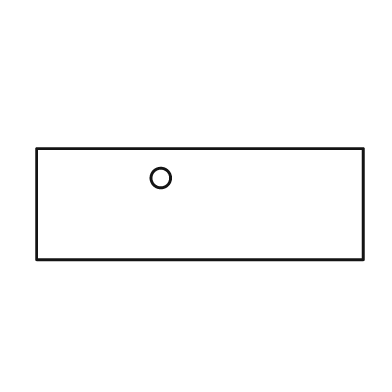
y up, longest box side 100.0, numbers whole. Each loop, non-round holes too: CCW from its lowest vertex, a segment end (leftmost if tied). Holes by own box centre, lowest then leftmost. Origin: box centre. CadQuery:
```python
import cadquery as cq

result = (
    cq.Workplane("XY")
    .moveTo(-50.0, -17.0)
    .lineTo(50.0, -17.0)
    .lineTo(50.0, 17.0)
    .lineTo(-50.0, 17.0)
    .close()
    .moveTo(-12.0, 8.0)
    .circle(3.0)
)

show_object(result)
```